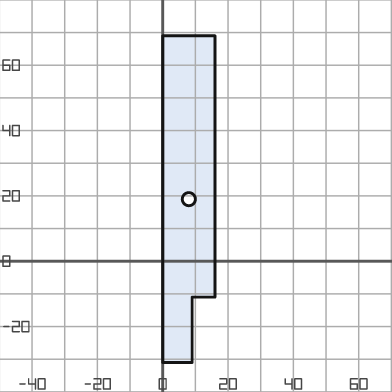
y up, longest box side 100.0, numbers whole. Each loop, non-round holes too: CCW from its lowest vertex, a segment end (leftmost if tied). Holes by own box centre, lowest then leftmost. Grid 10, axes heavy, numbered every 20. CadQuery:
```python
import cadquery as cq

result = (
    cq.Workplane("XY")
    .moveTo(0.0, -31.0)
    .lineTo(9.0, -31.0)
    .lineTo(9.0, -11.0)
    .lineTo(16.0, -11.0)
    .lineTo(16.0, 69.0)
    .lineTo(0.0, 69.0)
    .close()
    .moveTo(8.0, 19.0)
    .circle(2.0)
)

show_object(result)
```